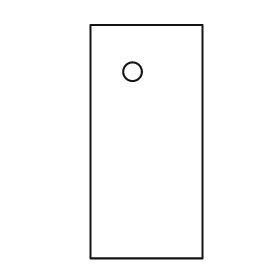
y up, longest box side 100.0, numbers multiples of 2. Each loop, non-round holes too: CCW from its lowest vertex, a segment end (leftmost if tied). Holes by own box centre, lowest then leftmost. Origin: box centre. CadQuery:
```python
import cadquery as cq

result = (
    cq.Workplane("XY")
    .moveTo(-24.0, -50.0)
    .lineTo(24.0, -50.0)
    .lineTo(24.0, 50.0)
    .lineTo(-24.0, 50.0)
    .close()
    .moveTo(-6.0, 30.0)
    .circle(4.0)
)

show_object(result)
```